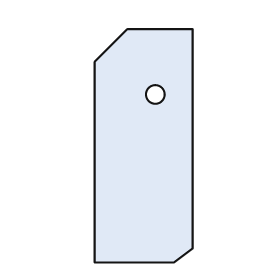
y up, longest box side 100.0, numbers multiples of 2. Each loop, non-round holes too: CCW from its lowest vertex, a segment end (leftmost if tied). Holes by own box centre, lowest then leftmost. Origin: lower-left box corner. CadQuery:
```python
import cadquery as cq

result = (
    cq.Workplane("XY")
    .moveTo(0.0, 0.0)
    .lineTo(34.0, 0.0)
    .lineTo(42.0, 6.0)
    .lineTo(42.0, 100.0)
    .lineTo(14.0, 100.0)
    .lineTo(0.0, 86.0)
    .close()
    .moveTo(26.0, 72.0)
    .circle(4.0)
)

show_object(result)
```